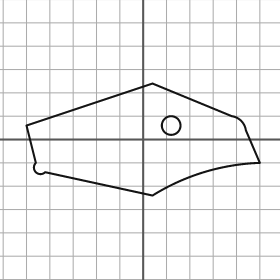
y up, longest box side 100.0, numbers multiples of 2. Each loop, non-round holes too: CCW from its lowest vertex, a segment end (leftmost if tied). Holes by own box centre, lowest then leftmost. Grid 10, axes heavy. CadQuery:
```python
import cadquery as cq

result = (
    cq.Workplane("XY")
    .moveTo(4.0, -24.0)
    .threePointArc((26.0, -14.0), (50.0, -10.0))
    .lineTo(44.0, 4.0)
    .threePointArc((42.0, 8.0), (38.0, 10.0))
    .lineTo(4.0, 24.0)
    .lineTo(-50.0, 6.0)
    .lineTo(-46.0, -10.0)
    .threePointArc((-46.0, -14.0), (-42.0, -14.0))
    .close()
    .moveTo(12.0, 6.0)
    .circle(4.0)
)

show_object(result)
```